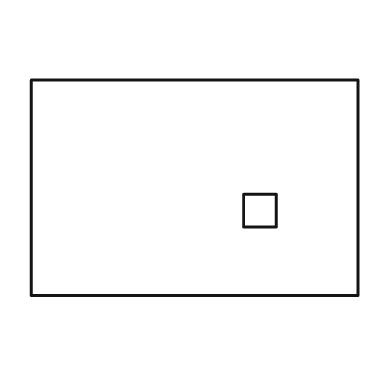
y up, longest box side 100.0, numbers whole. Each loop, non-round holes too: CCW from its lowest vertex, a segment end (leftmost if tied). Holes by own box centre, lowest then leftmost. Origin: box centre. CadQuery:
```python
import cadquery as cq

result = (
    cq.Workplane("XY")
    .moveTo(-50.0, -33.0)
    .lineTo(50.0, -33.0)
    .lineTo(50.0, 33.0)
    .lineTo(-50.0, 33.0)
    .close()
    .moveTo(15.0, -12.0)
    .lineTo(25.0, -12.0)
    .lineTo(25.0, -2.0)
    .lineTo(15.0, -2.0)
    .close()
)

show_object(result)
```